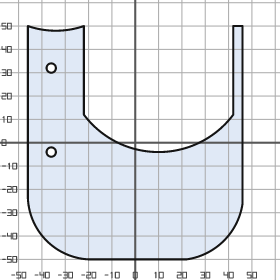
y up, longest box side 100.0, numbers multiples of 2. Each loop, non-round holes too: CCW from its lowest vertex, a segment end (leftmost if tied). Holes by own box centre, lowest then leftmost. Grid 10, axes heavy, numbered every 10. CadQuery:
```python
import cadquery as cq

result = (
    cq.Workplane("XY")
    .moveTo(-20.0, -50.0)
    .lineTo(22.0, -50.0)
    .threePointArc((38.0, -42.0), (46.0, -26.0))
    .lineTo(46.0, 50.0)
    .lineTo(42.0, 50.0)
    .lineTo(42.0, 12.0)
    .threePointArc((10.0, -4.0), (-22.0, 12.0))
    .lineTo(-22.0, 50.0)
    .threePointArc((-34.0, 48.0), (-46.0, 50.0))
    .lineTo(-46.0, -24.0)
    .threePointArc((-38.0, -42.0), (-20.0, -50.0))
    .close()
    .moveTo(-36.0, -4.0)
    .circle(2.0)
    .moveTo(-36.0, 32.0)
    .circle(2.0)
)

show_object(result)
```